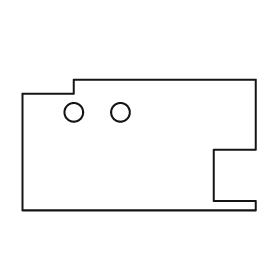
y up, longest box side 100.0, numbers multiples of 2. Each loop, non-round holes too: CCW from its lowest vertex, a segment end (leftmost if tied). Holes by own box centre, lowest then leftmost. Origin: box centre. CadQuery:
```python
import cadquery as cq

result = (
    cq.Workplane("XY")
    .moveTo(-50.0, -28.0)
    .lineTo(50.0, -28.0)
    .lineTo(50.0, -24.0)
    .lineTo(32.0, -24.0)
    .lineTo(32.0, -2.0)
    .lineTo(50.0, -2.0)
    .lineTo(50.0, 28.0)
    .lineTo(-28.0, 28.0)
    .lineTo(-28.0, 22.0)
    .lineTo(-50.0, 22.0)
    .close()
    .moveTo(-28.0, 14.0)
    .circle(4.0)
    .moveTo(-8.0, 14.0)
    .circle(4.0)
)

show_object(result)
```